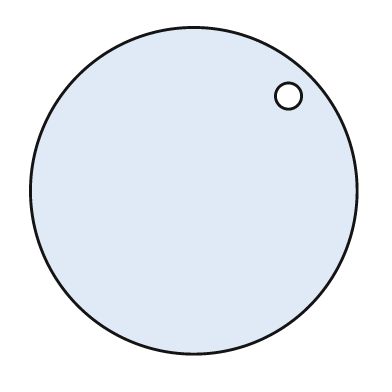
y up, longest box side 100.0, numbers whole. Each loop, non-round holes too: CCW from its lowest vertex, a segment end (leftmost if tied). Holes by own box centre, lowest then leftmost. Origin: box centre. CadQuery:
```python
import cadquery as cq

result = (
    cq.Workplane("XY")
    .moveTo(0.0, 0.0)
    .circle(50.0)
    .moveTo(29.0, 29.0)
    .circle(4.0)
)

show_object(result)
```